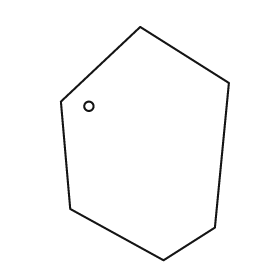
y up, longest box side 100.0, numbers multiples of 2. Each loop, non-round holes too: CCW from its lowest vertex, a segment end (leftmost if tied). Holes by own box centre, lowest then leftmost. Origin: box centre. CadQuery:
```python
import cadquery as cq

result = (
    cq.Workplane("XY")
    .moveTo(8.0, -50.0)
    .lineTo(30.0, -36.0)
    .lineTo(36.0, 26.0)
    .lineTo(-2.0, 50.0)
    .lineTo(-36.0, 18.0)
    .lineTo(-32.0, -28.0)
    .close()
    .moveTo(-24.0, 16.0)
    .circle(2.0)
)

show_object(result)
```